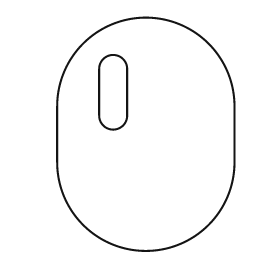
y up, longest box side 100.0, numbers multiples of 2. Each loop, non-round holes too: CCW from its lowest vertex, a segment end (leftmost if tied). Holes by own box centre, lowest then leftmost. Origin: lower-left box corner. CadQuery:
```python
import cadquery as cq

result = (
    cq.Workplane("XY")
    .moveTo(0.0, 38.0)
    .threePointArc((38.0, 0.0), (76.0, 38.0))
    .lineTo(76.0, 62.0)
    .threePointArc((38.0, 100.0), (0.0, 62.0))
    .close()
    .moveTo(18.0, 58.0)
    .threePointArc((24.0, 52.0), (30.0, 58.0))
    .lineTo(30.0, 78.0)
    .threePointArc((24.0, 84.0), (18.0, 78.0))
    .close()
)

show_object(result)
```